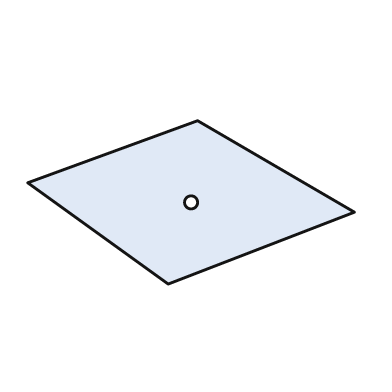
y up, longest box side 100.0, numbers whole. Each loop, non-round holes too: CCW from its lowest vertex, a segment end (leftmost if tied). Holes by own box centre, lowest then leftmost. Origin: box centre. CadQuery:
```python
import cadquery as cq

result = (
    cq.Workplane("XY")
    .moveTo(-7.0, -25.0)
    .lineTo(50.0, -3.0)
    .lineTo(2.0, 25.0)
    .lineTo(-50.0, 6.0)
    .close()
    .moveTo(0.0, 0.0)
    .circle(2.0)
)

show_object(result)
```